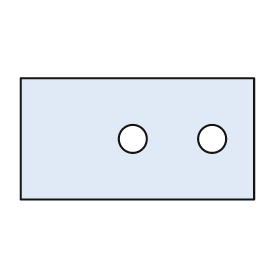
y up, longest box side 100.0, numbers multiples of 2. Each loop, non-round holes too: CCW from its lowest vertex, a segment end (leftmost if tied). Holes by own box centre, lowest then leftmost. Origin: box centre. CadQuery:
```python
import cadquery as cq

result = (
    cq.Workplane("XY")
    .moveTo(-50.0, -26.0)
    .lineTo(50.0, -26.0)
    .lineTo(50.0, 26.0)
    .lineTo(-50.0, 26.0)
    .close()
    .moveTo(-2.0, 0.0)
    .circle(6.0)
    .moveTo(32.0, 0.0)
    .circle(6.0)
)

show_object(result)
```